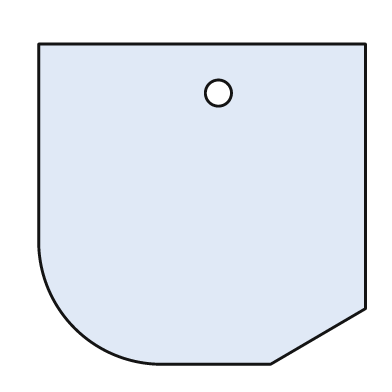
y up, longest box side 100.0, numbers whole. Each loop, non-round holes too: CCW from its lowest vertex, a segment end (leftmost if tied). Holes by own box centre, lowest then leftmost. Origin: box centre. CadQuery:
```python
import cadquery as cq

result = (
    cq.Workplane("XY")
    .moveTo(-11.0, -49.0)
    .lineTo(21.0, -49.0)
    .lineTo(50.0, -32.0)
    .lineTo(50.0, 49.0)
    .lineTo(-50.0, 49.0)
    .lineTo(-50.0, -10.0)
    .threePointArc((-39.0, -38.0), (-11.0, -49.0))
    .close()
    .moveTo(5.0, 34.0)
    .circle(4.0)
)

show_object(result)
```